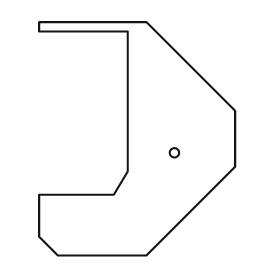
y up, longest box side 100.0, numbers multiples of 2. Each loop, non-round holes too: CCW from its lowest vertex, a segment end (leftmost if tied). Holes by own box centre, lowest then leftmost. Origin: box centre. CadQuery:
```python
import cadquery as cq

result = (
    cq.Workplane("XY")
    .moveTo(-34.0, -50.0)
    .lineTo(4.0, -50.0)
    .lineTo(42.0, -12.0)
    .lineTo(42.0, 12.0)
    .lineTo(4.0, 50.0)
    .lineTo(-42.0, 50.0)
    .lineTo(-42.0, 46.0)
    .lineTo(-4.0, 46.0)
    .lineTo(-4.0, -14.0)
    .lineTo(-10.0, -24.0)
    .lineTo(-42.0, -24.0)
    .lineTo(-42.0, -42.0)
    .close()
    .moveTo(16.0, -6.0)
    .circle(2.0)
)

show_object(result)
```